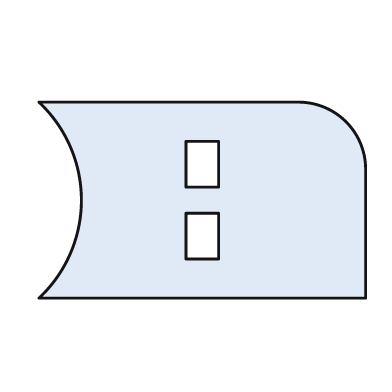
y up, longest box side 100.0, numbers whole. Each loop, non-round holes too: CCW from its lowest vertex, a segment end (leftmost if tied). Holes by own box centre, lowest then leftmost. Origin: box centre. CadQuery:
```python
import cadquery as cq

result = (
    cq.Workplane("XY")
    .moveTo(-50.0, -30.0)
    .lineTo(50.0, -30.0)
    .lineTo(50.0, 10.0)
    .threePointArc((44.0, 24.0), (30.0, 30.0))
    .lineTo(-50.0, 30.0)
    .threePointArc((-37.0, 0.0), (-50.0, -30.0))
    .close()
    .moveTo(-5.0, -18.0)
    .lineTo(5.0, -18.0)
    .lineTo(5.0, -4.0)
    .lineTo(-5.0, -4.0)
    .close()
    .moveTo(-5.0, 4.0)
    .lineTo(5.0, 4.0)
    .lineTo(5.0, 18.0)
    .lineTo(-5.0, 18.0)
    .close()
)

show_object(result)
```